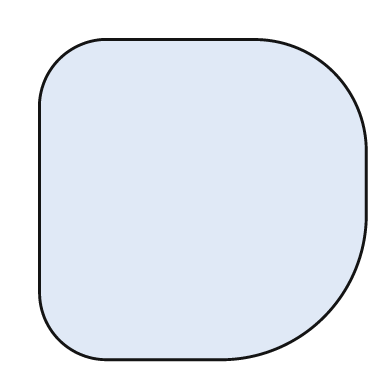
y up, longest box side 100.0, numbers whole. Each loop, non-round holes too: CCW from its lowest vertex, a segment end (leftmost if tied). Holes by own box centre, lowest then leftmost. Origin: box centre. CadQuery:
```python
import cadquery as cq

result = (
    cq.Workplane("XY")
    .moveTo(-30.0, -49.0)
    .lineTo(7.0, -49.0)
    .threePointArc((37.0, -36.0), (50.0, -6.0))
    .lineTo(50.0, 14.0)
    .threePointArc((40.0, 39.0), (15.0, 49.0))
    .lineTo(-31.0, 49.0)
    .threePointArc((-44.0, 43.0), (-50.0, 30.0))
    .lineTo(-50.0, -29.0)
    .threePointArc((-44.0, -43.0), (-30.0, -49.0))
    .close()
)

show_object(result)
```